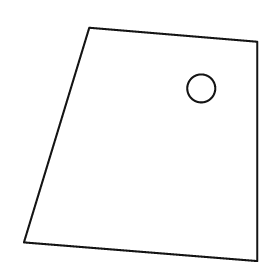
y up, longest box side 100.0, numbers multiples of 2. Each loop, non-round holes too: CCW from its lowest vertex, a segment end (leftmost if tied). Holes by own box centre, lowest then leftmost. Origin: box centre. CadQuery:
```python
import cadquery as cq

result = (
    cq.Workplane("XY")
    .moveTo(50.0, -50.0)
    .lineTo(50.0, 44.0)
    .lineTo(-22.0, 50.0)
    .lineTo(-50.0, -42.0)
    .close()
    .moveTo(26.0, 24.0)
    .circle(6.0)
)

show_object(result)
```